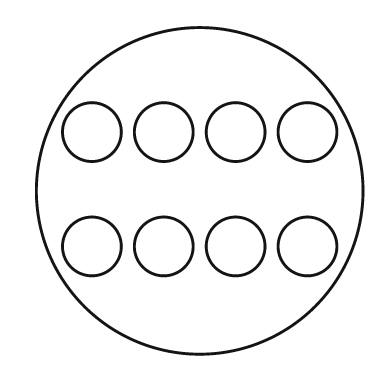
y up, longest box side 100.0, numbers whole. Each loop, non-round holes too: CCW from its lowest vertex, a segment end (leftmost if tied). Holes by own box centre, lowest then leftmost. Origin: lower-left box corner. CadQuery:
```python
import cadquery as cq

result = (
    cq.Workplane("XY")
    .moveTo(50.0, 50.0)
    .circle(50.0)
    .moveTo(17.0, 33.0)
    .circle(9.0)
    .moveTo(39.0, 33.0)
    .circle(9.0)
    .moveTo(61.0, 33.0)
    .circle(9.0)
    .moveTo(83.0, 33.0)
    .circle(9.0)
    .moveTo(17.0, 68.0)
    .circle(9.0)
    .moveTo(39.0, 68.0)
    .circle(9.0)
    .moveTo(61.0, 68.0)
    .circle(9.0)
    .moveTo(83.0, 68.0)
    .circle(9.0)
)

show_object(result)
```